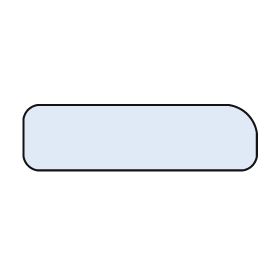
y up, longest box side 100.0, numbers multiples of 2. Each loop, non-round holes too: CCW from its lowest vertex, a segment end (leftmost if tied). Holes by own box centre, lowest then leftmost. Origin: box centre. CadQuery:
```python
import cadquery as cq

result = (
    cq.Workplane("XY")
    .moveTo(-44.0, -14.0)
    .lineTo(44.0, -14.0)
    .threePointArc((48.0, -12.0), (50.0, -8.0))
    .lineTo(50.0, 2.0)
    .threePointArc((46.0, 10.0), (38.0, 14.0))
    .lineTo(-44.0, 14.0)
    .threePointArc((-48.0, 12.0), (-50.0, 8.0))
    .lineTo(-50.0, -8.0)
    .threePointArc((-48.0, -12.0), (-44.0, -14.0))
    .close()
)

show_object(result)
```